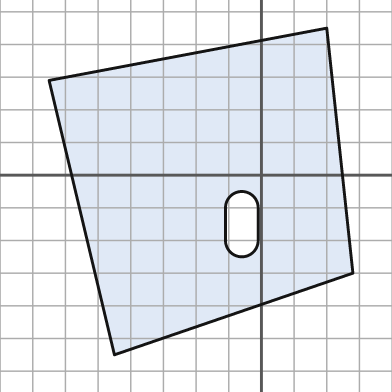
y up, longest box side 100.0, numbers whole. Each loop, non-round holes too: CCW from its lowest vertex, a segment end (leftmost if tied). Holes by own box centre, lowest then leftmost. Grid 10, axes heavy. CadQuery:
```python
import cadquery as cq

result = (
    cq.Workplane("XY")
    .moveTo(-45.0, -55.0)
    .lineTo(28.0, -30.0)
    .lineTo(20.0, 45.0)
    .lineTo(-65.0, 29.0)
    .close()
    .moveTo(-11.0, -20.0)
    .threePointArc((-6.0, -25.0), (-1.0, -20.0))
    .lineTo(-1.0, -10.0)
    .threePointArc((-6.0, -5.0), (-11.0, -10.0))
    .close()
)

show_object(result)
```